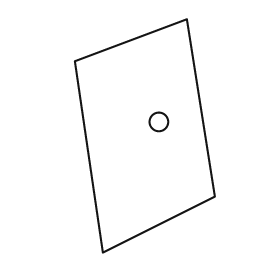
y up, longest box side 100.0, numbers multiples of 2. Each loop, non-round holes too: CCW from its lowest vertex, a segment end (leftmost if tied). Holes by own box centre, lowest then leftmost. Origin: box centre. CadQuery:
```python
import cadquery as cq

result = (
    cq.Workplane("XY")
    .moveTo(-18.0, -50.0)
    .lineTo(30.0, -26.0)
    .lineTo(18.0, 50.0)
    .lineTo(-30.0, 32.0)
    .close()
    .moveTo(6.0, 6.0)
    .circle(4.0)
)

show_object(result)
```